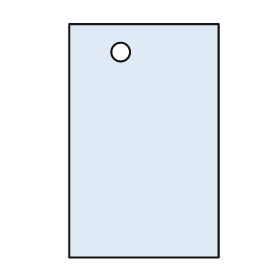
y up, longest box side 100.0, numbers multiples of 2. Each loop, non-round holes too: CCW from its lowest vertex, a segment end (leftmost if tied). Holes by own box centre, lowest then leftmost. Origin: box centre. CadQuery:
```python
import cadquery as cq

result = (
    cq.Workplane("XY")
    .moveTo(-32.0, -50.0)
    .lineTo(32.0, -50.0)
    .lineTo(32.0, 50.0)
    .lineTo(-32.0, 50.0)
    .close()
    .moveTo(-10.0, 38.0)
    .circle(4.0)
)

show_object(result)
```